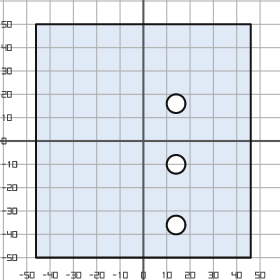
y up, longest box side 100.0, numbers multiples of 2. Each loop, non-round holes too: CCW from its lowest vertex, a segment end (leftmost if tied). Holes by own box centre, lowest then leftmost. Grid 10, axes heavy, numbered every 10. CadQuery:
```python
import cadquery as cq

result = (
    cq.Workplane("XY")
    .moveTo(-46.0, -50.0)
    .lineTo(46.0, -50.0)
    .lineTo(46.0, 50.0)
    .lineTo(-46.0, 50.0)
    .close()
    .moveTo(14.0, -36.0)
    .circle(4.0)
    .moveTo(14.0, -10.0)
    .circle(4.0)
    .moveTo(14.0, 16.0)
    .circle(4.0)
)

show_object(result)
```